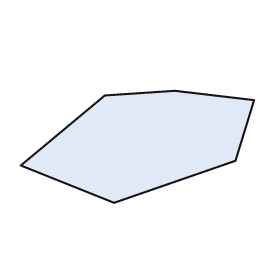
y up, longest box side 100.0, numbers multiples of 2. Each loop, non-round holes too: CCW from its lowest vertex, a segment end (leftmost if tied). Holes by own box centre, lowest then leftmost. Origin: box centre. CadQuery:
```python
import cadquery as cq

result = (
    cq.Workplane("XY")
    .moveTo(-10.0, -24.0)
    .lineTo(42.0, -6.0)
    .lineTo(50.0, 20.0)
    .lineTo(16.0, 24.0)
    .lineTo(-14.0, 22.0)
    .lineTo(-50.0, -8.0)
    .close()
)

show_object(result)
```